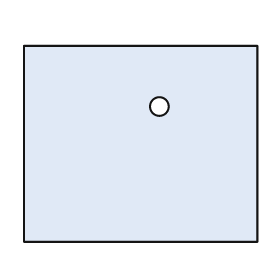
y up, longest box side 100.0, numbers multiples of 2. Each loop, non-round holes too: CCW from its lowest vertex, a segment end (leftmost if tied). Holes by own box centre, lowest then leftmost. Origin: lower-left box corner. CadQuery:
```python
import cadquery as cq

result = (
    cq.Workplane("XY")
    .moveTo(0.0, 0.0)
    .lineTo(100.0, 0.0)
    .lineTo(100.0, 84.0)
    .lineTo(0.0, 84.0)
    .close()
    .moveTo(58.0, 58.0)
    .circle(4.0)
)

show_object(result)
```